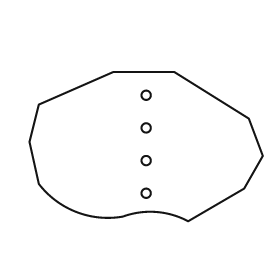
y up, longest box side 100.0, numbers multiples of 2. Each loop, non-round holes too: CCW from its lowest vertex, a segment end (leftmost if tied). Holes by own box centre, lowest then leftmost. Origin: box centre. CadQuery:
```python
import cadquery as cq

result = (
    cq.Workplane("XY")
    .moveTo(18.0, -32.0)
    .lineTo(42.0, -18.0)
    .lineTo(50.0, -4.0)
    .lineTo(44.0, 12.0)
    .lineTo(12.0, 32.0)
    .lineTo(-14.0, 32.0)
    .lineTo(-46.0, 18.0)
    .lineTo(-50.0, 2.0)
    .lineTo(-46.0, -16.0)
    .threePointArc((-30.0, -28.0), (-10.0, -30.0))
    .threePointArc((4.0, -28.0), (18.0, -32.0))
    .close()
    .moveTo(0.0, -20.0)
    .circle(2.0)
    .moveTo(0.0, -6.0)
    .circle(2.0)
    .moveTo(0.0, 8.0)
    .circle(2.0)
    .moveTo(0.0, 22.0)
    .circle(2.0)
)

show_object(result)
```